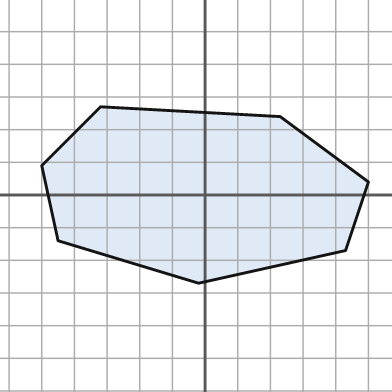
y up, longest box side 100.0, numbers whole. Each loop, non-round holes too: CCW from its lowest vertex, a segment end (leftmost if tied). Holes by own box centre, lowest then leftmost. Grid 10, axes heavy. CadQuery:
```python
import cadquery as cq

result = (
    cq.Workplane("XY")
    .moveTo(-2.0, -27.0)
    .lineTo(43.0, -17.0)
    .lineTo(50.0, 4.0)
    .lineTo(23.0, 24.0)
    .lineTo(-32.0, 27.0)
    .lineTo(-50.0, 9.0)
    .lineTo(-45.0, -14.0)
    .close()
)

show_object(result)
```